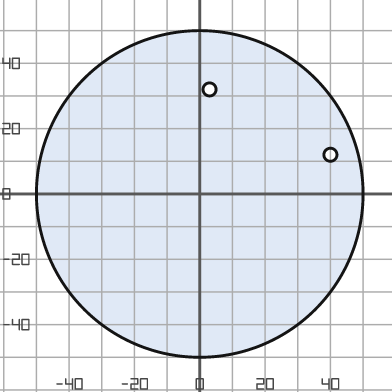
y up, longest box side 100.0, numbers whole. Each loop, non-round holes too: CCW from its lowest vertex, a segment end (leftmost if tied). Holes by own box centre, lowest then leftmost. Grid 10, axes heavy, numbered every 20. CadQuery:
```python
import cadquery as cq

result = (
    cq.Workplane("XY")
    .moveTo(0.0, 0.0)
    .circle(50.0)
    .moveTo(40.0, 12.0)
    .circle(2.0)
    .moveTo(3.0, 32.0)
    .circle(2.0)
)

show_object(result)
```